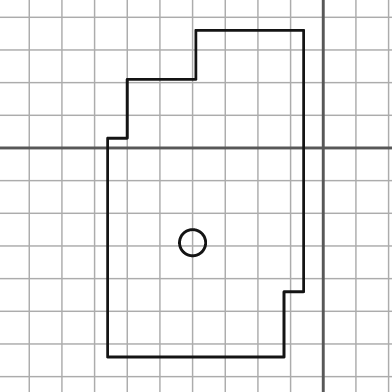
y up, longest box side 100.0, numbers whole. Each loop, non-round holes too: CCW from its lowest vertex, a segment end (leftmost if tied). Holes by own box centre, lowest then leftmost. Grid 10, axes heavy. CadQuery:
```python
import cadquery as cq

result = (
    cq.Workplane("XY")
    .moveTo(-66.0, -64.0)
    .lineTo(-12.0, -64.0)
    .lineTo(-12.0, -44.0)
    .lineTo(-6.0, -44.0)
    .lineTo(-6.0, 36.0)
    .lineTo(-39.0, 36.0)
    .lineTo(-39.0, 21.0)
    .lineTo(-60.0, 21.0)
    .lineTo(-60.0, 3.0)
    .lineTo(-66.0, 3.0)
    .close()
    .moveTo(-40.0, -29.0)
    .circle(4.0)
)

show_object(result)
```